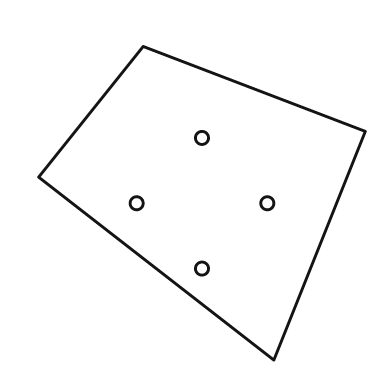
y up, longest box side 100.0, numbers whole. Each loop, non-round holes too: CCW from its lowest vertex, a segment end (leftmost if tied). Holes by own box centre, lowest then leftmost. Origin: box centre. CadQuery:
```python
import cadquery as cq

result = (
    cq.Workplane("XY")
    .moveTo(22.0, -48.0)
    .lineTo(50.0, 22.0)
    .lineTo(-18.0, 48.0)
    .lineTo(-50.0, 8.0)
    .close()
    .moveTo(0.0, -20.0)
    .circle(2.0)
    .moveTo(-20.0, 0.0)
    .circle(2.0)
    .moveTo(20.0, 0.0)
    .circle(2.0)
    .moveTo(0.0, 20.0)
    .circle(2.0)
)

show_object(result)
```